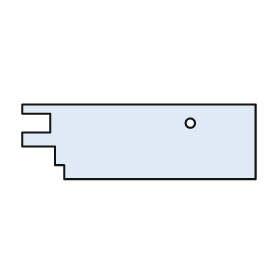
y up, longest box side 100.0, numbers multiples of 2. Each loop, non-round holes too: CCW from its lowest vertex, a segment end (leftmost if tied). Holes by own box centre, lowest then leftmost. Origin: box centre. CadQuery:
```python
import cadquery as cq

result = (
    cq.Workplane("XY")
    .moveTo(-32.0, -16.0)
    .lineTo(50.0, -16.0)
    .lineTo(50.0, 16.0)
    .lineTo(-50.0, 16.0)
    .lineTo(-50.0, 12.0)
    .lineTo(-38.0, 12.0)
    .lineTo(-38.0, 4.0)
    .lineTo(-50.0, 4.0)
    .lineTo(-50.0, -2.0)
    .lineTo(-36.0, -2.0)
    .lineTo(-36.0, -10.0)
    .lineTo(-32.0, -10.0)
    .close()
    .moveTo(22.0, 8.0)
    .circle(2.0)
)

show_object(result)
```